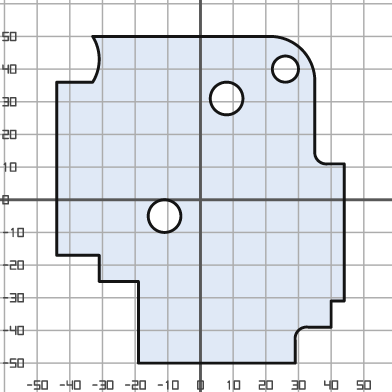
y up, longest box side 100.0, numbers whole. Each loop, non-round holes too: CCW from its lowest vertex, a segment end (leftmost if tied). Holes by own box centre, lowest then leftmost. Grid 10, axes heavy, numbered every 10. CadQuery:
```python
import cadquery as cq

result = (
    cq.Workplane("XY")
    .moveTo(-19.0, -50.0)
    .lineTo(29.0, -50.0)
    .lineTo(29.0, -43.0)
    .threePointArc((30.0, -40.0), (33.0, -39.0))
    .lineTo(40.0, -39.0)
    .lineTo(40.0, -31.0)
    .lineTo(44.0, -31.0)
    .lineTo(44.0, 11.0)
    .lineTo(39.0, 11.0)
    .threePointArc((36.0, 12.0), (35.0, 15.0))
    .lineTo(35.0, 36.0)
    .threePointArc((31.0, 46.0), (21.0, 50.0))
    .lineTo(-33.0, 50.0)
    .threePointArc((-31.0, 43.0), (-33.0, 36.0))
    .lineTo(-44.0, 36.0)
    .lineTo(-44.0, -17.0)
    .lineTo(-31.0, -17.0)
    .lineTo(-31.0, -25.0)
    .lineTo(-19.0, -25.0)
    .close()
    .moveTo(-11.0, -5.0)
    .circle(5.0)
    .moveTo(8.0, 31.0)
    .circle(5.0)
    .moveTo(26.0, 40.0)
    .circle(4.0)
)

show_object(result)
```